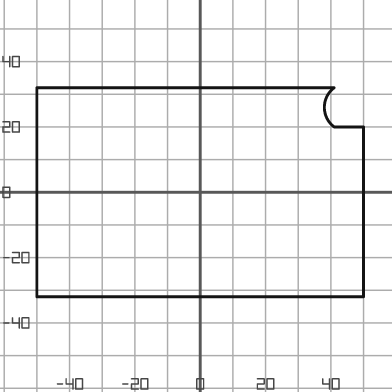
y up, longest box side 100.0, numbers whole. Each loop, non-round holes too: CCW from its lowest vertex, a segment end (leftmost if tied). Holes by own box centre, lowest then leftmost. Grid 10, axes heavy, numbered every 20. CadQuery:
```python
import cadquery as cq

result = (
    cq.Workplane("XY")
    .moveTo(-50.0, -32.0)
    .lineTo(50.0, -32.0)
    .lineTo(50.0, 20.0)
    .lineTo(41.0, 20.0)
    .threePointArc((38.0, 26.0), (41.0, 32.0))
    .lineTo(-50.0, 32.0)
    .close()
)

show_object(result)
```